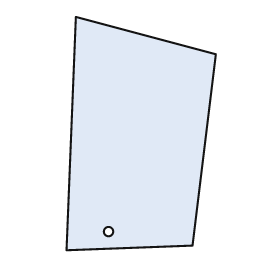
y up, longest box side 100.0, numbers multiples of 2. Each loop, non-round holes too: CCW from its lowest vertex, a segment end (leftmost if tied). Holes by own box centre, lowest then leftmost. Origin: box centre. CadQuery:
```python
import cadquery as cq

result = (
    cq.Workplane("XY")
    .moveTo(-32.0, -50.0)
    .lineTo(22.0, -48.0)
    .lineTo(32.0, 34.0)
    .lineTo(-28.0, 50.0)
    .close()
    .moveTo(-14.0, -42.0)
    .circle(2.0)
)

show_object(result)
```